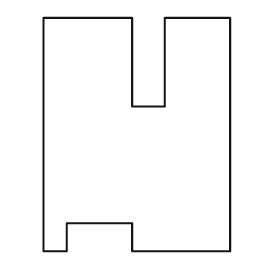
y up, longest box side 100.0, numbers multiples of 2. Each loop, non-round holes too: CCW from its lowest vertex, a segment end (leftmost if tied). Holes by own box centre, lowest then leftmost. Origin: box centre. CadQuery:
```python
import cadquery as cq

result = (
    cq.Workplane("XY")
    .moveTo(-40.0, -50.0)
    .lineTo(-30.0, -50.0)
    .lineTo(-30.0, -38.0)
    .lineTo(-2.0, -38.0)
    .lineTo(-2.0, -50.0)
    .lineTo(40.0, -50.0)
    .lineTo(40.0, 50.0)
    .lineTo(12.0, 50.0)
    .lineTo(12.0, 12.0)
    .lineTo(-2.0, 12.0)
    .lineTo(-2.0, 50.0)
    .lineTo(-40.0, 50.0)
    .close()
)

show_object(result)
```